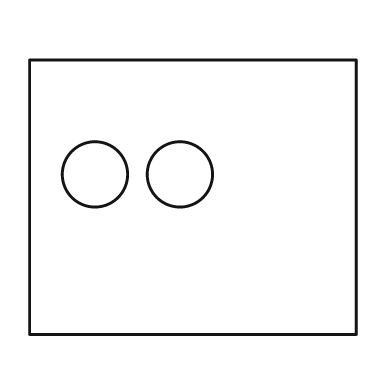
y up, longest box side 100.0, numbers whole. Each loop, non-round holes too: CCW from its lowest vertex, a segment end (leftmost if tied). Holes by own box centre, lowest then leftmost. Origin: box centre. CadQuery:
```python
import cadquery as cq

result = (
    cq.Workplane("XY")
    .moveTo(-50.0, -42.0)
    .lineTo(50.0, -42.0)
    .lineTo(50.0, 42.0)
    .lineTo(-50.0, 42.0)
    .close()
    .moveTo(-30.0, 7.0)
    .circle(10.0)
    .moveTo(-4.0, 7.0)
    .circle(10.0)
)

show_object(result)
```